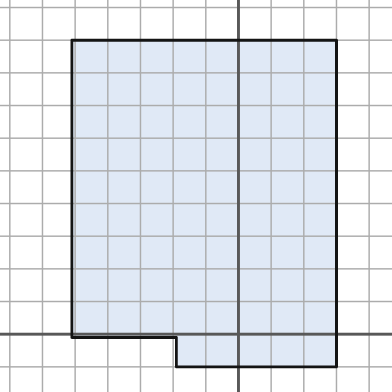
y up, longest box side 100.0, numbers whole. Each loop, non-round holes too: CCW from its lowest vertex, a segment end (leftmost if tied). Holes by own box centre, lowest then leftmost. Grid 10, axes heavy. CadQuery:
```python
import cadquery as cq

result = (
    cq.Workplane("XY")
    .moveTo(-19.0, -10.0)
    .lineTo(30.0, -10.0)
    .lineTo(30.0, 90.0)
    .lineTo(-51.0, 90.0)
    .lineTo(-51.0, -1.0)
    .lineTo(-19.0, -1.0)
    .close()
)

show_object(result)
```